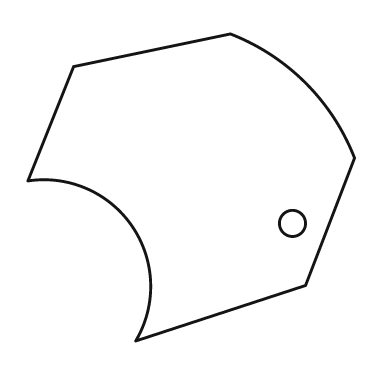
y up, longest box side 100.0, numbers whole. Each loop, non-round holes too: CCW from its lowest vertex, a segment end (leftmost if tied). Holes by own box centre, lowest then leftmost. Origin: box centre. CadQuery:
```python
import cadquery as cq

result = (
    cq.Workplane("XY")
    .moveTo(-17.0, -47.0)
    .lineTo(35.0, -30.0)
    .lineTo(50.0, 9.0)
    .threePointArc((35.0, 32.0), (12.0, 47.0))
    .lineTo(-36.0, 37.0)
    .lineTo(-50.0, 2.0)
    .threePointArc((-18.0, -12.0), (-17.0, -47.0))
    .close()
    .moveTo(31.0, -11.0)
    .circle(4.0)
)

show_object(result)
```